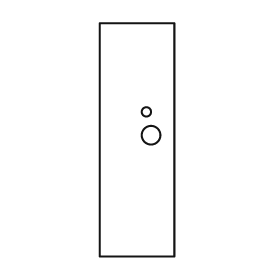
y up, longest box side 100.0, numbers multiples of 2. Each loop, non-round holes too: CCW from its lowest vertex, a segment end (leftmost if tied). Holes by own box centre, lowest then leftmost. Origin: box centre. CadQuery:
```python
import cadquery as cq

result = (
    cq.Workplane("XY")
    .moveTo(-16.0, -50.0)
    .lineTo(16.0, -50.0)
    .lineTo(16.0, 50.0)
    .lineTo(-16.0, 50.0)
    .close()
    .moveTo(6.0, 2.0)
    .circle(4.0)
    .moveTo(4.0, 12.0)
    .circle(2.0)
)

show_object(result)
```